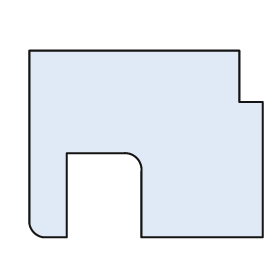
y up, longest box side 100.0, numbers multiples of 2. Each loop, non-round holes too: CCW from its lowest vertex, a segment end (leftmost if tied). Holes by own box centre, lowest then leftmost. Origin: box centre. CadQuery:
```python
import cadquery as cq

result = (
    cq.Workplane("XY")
    .moveTo(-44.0, -40.0)
    .lineTo(-34.0, -40.0)
    .lineTo(-34.0, -4.0)
    .lineTo(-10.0, -4.0)
    .threePointArc((-4.0, -6.0), (-2.0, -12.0))
    .lineTo(-2.0, -40.0)
    .lineTo(50.0, -40.0)
    .lineTo(50.0, 18.0)
    .lineTo(40.0, 18.0)
    .lineTo(40.0, 40.0)
    .lineTo(-50.0, 40.0)
    .lineTo(-50.0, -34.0)
    .threePointArc((-48.0, -38.0), (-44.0, -40.0))
    .close()
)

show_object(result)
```